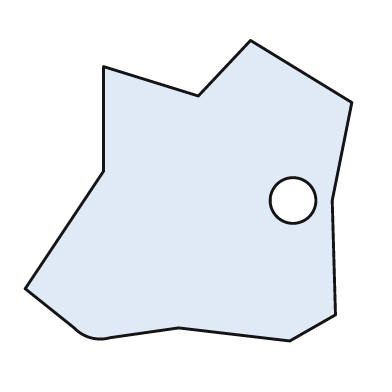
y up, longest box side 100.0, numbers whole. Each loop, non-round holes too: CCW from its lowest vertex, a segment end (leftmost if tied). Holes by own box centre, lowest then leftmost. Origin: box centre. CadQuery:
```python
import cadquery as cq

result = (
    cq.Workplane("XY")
    .moveTo(31.0, -46.0)
    .lineTo(45.0, -38.0)
    .lineTo(44.0, -3.0)
    .lineTo(50.0, 27.0)
    .lineTo(19.0, 46.0)
    .lineTo(3.0, 29.0)
    .lineTo(-26.0, 38.0)
    .lineTo(-26.0, 6.0)
    .lineTo(-50.0, -30.0)
    .lineTo(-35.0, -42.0)
    .threePointArc((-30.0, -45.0), (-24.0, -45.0))
    .lineTo(-3.0, -42.0)
    .close()
    .moveTo(32.0, -3.0)
    .circle(7.0)
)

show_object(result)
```